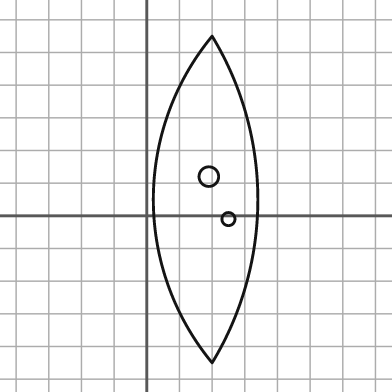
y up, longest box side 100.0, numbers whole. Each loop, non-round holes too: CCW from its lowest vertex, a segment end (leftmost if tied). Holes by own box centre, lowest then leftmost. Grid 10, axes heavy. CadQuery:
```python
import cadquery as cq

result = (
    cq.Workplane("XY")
    .moveTo(20.0, -45.0)
    .threePointArc((34.0, 5.0), (20.0, 55.0))
    .threePointArc((2.0, 5.0), (20.0, -45.0))
    .close()
    .moveTo(25.0, -1.0)
    .circle(2.0)
    .moveTo(19.0, 12.0)
    .circle(3.0)
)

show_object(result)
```